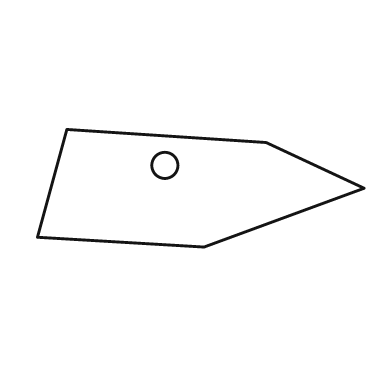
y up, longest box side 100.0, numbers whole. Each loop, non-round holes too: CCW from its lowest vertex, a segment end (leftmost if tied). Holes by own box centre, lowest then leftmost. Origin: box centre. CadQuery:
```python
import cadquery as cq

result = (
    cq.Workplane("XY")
    .moveTo(1.0, -18.0)
    .lineTo(50.0, 0.0)
    .lineTo(20.0, 14.0)
    .lineTo(-41.0, 18.0)
    .lineTo(-50.0, -15.0)
    .close()
    .moveTo(-11.0, 7.0)
    .circle(4.0)
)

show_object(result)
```